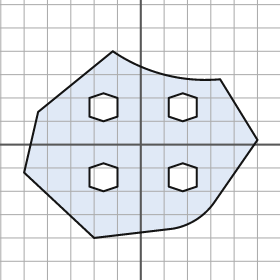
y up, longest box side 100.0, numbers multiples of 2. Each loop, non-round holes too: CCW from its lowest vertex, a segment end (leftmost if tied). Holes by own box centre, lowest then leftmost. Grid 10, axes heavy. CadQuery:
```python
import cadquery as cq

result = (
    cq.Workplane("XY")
    .moveTo(-20.0, -40.0)
    .lineTo(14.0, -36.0)
    .threePointArc((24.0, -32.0), (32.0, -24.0))
    .lineTo(50.0, 2.0)
    .lineTo(34.0, 28.0)
    .threePointArc((10.0, 30.0), (-12.0, 40.0))
    .lineTo(-44.0, 14.0)
    .lineTo(-50.0, -12.0)
    .close()
    .moveTo(-16.0, -20.0)
    .lineTo(-10.0, -18.0)
    .lineTo(-10.0, -10.0)
    .lineTo(-16.0, -8.0)
    .lineTo(-22.0, -10.0)
    .lineTo(-22.0, -18.0)
    .close()
    .moveTo(18.0, -20.0)
    .lineTo(24.0, -18.0)
    .lineTo(24.0, -10.0)
    .lineTo(18.0, -8.0)
    .lineTo(12.0, -10.0)
    .lineTo(12.0, -18.0)
    .close()
    .moveTo(-16.0, 10.0)
    .lineTo(-10.0, 12.0)
    .lineTo(-10.0, 20.0)
    .lineTo(-16.0, 22.0)
    .lineTo(-22.0, 20.0)
    .lineTo(-22.0, 12.0)
    .close()
    .moveTo(18.0, 10.0)
    .lineTo(24.0, 12.0)
    .lineTo(24.0, 20.0)
    .lineTo(18.0, 22.0)
    .lineTo(12.0, 20.0)
    .lineTo(12.0, 12.0)
    .close()
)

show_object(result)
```